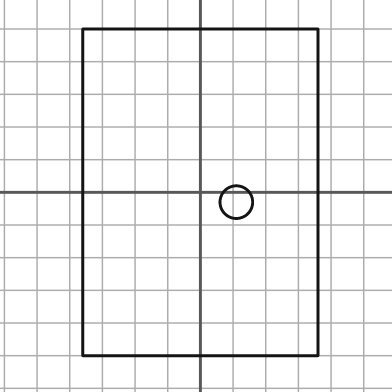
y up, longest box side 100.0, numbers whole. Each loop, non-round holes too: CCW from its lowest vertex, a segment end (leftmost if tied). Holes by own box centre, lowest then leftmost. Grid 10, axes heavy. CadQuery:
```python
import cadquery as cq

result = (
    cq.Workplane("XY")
    .moveTo(-36.0, -50.0)
    .lineTo(36.0, -50.0)
    .lineTo(36.0, 50.0)
    .lineTo(-36.0, 50.0)
    .close()
    .moveTo(11.0, -3.0)
    .circle(5.0)
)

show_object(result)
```